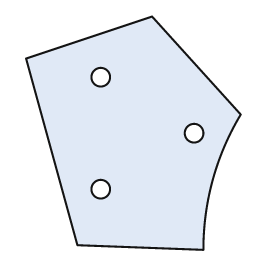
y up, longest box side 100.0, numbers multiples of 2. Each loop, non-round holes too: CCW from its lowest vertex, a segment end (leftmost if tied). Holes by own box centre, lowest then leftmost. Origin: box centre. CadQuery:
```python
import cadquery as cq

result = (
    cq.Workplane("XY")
    .moveTo(30.0, -50.0)
    .threePointArc((34.0, -20.0), (46.0, 8.0))
    .lineTo(8.0, 50.0)
    .lineTo(-46.0, 32.0)
    .lineTo(-24.0, -48.0)
    .close()
    .moveTo(-14.0, -24.0)
    .circle(4.0)
    .moveTo(26.0, 0.0)
    .circle(4.0)
    .moveTo(-14.0, 24.0)
    .circle(4.0)
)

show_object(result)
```